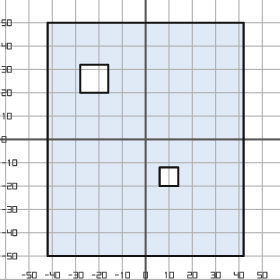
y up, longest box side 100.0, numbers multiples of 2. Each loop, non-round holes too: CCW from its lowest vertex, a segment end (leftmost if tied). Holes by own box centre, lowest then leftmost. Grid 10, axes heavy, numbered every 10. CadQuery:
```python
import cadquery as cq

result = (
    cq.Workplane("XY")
    .moveTo(-42.0, -50.0)
    .lineTo(42.0, -50.0)
    .lineTo(42.0, 50.0)
    .lineTo(-42.0, 50.0)
    .close()
    .moveTo(6.0, -20.0)
    .lineTo(14.0, -20.0)
    .lineTo(14.0, -12.0)
    .lineTo(6.0, -12.0)
    .close()
    .moveTo(-28.0, 20.0)
    .lineTo(-16.0, 20.0)
    .lineTo(-16.0, 32.0)
    .lineTo(-28.0, 32.0)
    .close()
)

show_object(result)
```